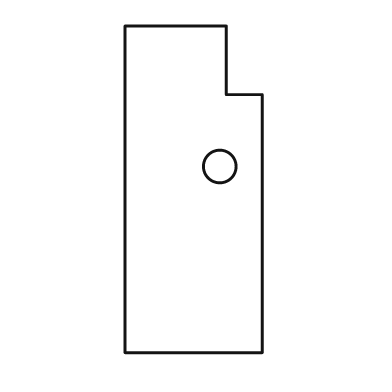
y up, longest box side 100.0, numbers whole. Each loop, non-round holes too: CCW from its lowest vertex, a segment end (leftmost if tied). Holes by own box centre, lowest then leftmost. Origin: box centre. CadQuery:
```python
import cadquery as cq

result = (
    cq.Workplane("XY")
    .moveTo(-21.0, -50.0)
    .lineTo(21.0, -50.0)
    .lineTo(21.0, 29.0)
    .lineTo(10.0, 29.0)
    .lineTo(10.0, 50.0)
    .lineTo(-21.0, 50.0)
    .close()
    .moveTo(8.0, 7.0)
    .circle(5.0)
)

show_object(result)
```